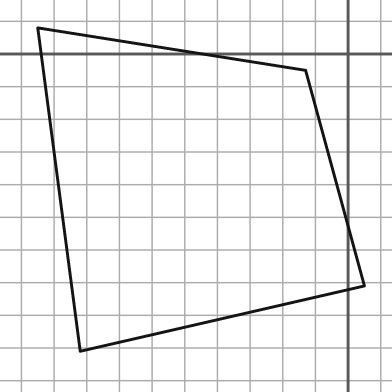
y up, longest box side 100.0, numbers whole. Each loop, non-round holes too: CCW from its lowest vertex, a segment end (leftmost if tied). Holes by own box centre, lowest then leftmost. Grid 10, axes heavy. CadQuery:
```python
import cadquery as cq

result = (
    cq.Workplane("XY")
    .moveTo(-82.0, -91.0)
    .lineTo(5.0, -71.0)
    .lineTo(-13.0, -5.0)
    .lineTo(-95.0, 8.0)
    .close()
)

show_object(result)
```